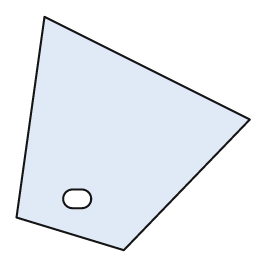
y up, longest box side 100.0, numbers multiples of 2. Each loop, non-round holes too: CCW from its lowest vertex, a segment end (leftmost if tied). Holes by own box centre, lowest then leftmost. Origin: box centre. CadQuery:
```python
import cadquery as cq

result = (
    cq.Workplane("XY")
    .moveTo(-4.0, -50.0)
    .lineTo(50.0, 6.0)
    .lineTo(-38.0, 50.0)
    .lineTo(-50.0, -36.0)
    .close()
    .moveTo(-26.0, -32.0)
    .lineTo(-22.0, -32.0)
    .threePointArc((-18.0, -28.0), (-22.0, -24.0))
    .lineTo(-26.0, -24.0)
    .threePointArc((-30.0, -28.0), (-26.0, -32.0))
    .close()
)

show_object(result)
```